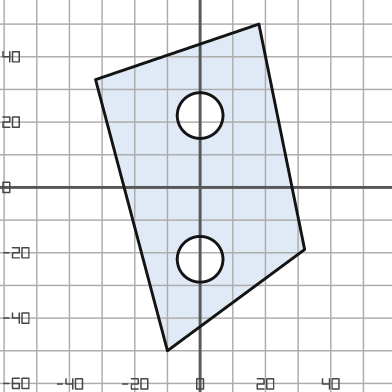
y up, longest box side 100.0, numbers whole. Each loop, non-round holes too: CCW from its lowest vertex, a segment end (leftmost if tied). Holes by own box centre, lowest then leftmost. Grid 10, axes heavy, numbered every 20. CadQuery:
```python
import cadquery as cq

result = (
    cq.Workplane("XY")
    .moveTo(-10.0, -50.0)
    .lineTo(32.0, -19.0)
    .lineTo(18.0, 50.0)
    .lineTo(-32.0, 33.0)
    .close()
    .moveTo(0.0, -22.0)
    .circle(7.0)
    .moveTo(0.0, 22.0)
    .circle(7.0)
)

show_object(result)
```